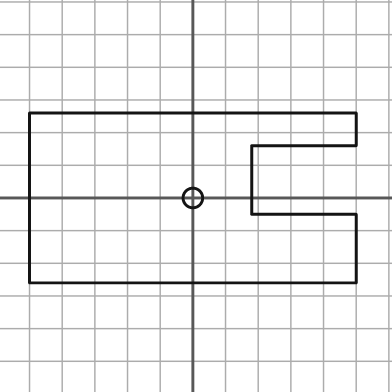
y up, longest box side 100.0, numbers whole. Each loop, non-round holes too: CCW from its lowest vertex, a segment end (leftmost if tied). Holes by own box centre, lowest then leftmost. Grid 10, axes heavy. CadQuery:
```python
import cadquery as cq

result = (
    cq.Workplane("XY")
    .moveTo(-50.0, -26.0)
    .lineTo(50.0, -26.0)
    .lineTo(50.0, -5.0)
    .lineTo(18.0, -5.0)
    .lineTo(18.0, 16.0)
    .lineTo(50.0, 16.0)
    .lineTo(50.0, 26.0)
    .lineTo(-50.0, 26.0)
    .close()
    .moveTo(0.0, 0.0)
    .circle(3.0)
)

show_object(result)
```